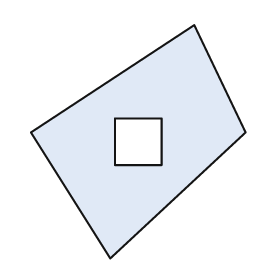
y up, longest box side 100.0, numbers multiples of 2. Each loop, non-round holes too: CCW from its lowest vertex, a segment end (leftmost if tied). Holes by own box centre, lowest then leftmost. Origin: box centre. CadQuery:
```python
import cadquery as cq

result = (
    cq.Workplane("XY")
    .moveTo(-12.0, -50.0)
    .lineTo(46.0, 4.0)
    .lineTo(24.0, 50.0)
    .lineTo(-46.0, 4.0)
    .close()
    .moveTo(-10.0, -10.0)
    .lineTo(10.0, -10.0)
    .lineTo(10.0, 10.0)
    .lineTo(-10.0, 10.0)
    .close()
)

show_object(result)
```